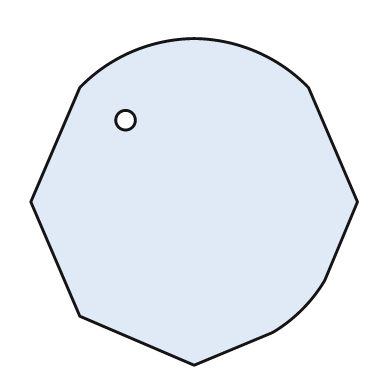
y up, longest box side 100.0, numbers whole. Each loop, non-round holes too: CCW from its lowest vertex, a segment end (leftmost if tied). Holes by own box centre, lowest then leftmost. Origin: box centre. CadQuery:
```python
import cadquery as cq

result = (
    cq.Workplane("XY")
    .moveTo(0.0, -50.0)
    .lineTo(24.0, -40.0)
    .threePointArc((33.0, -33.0), (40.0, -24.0))
    .lineTo(50.0, 0.0)
    .lineTo(35.0, 35.0)
    .threePointArc((19.0, 46.0), (0.0, 50.0))
    .threePointArc((-19.0, 46.0), (-35.0, 35.0))
    .lineTo(-50.0, 0.0)
    .lineTo(-35.0, -35.0)
    .close()
    .moveTo(-21.0, 25.0)
    .circle(3.0)
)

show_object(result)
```